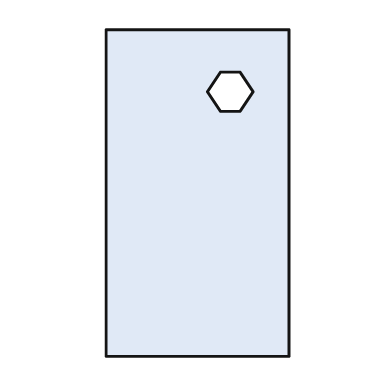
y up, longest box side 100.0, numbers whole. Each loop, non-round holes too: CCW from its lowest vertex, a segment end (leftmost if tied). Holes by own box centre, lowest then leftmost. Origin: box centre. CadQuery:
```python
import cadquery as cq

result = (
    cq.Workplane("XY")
    .moveTo(-28.0, -50.0)
    .lineTo(28.0, -50.0)
    .lineTo(28.0, 50.0)
    .lineTo(-28.0, 50.0)
    .close()
    .moveTo(7.0, 25.0)
    .lineTo(13.0, 25.0)
    .lineTo(17.0, 31.0)
    .lineTo(13.0, 37.0)
    .lineTo(7.0, 37.0)
    .lineTo(3.0, 31.0)
    .close()
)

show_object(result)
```